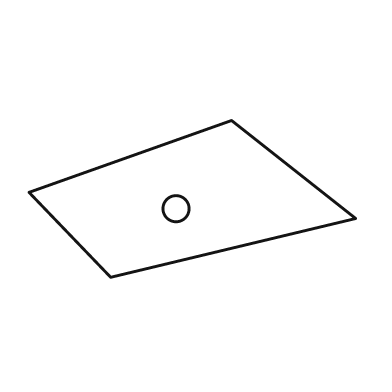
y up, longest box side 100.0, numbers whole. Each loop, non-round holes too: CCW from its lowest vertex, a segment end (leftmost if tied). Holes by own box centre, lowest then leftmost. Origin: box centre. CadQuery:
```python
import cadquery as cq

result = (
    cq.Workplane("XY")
    .moveTo(-25.0, -24.0)
    .lineTo(50.0, -6.0)
    .lineTo(12.0, 24.0)
    .lineTo(-50.0, 2.0)
    .close()
    .moveTo(-5.0, -3.0)
    .circle(4.0)
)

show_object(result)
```